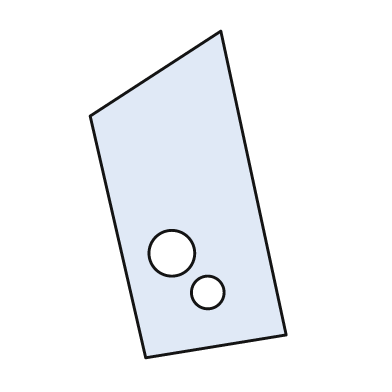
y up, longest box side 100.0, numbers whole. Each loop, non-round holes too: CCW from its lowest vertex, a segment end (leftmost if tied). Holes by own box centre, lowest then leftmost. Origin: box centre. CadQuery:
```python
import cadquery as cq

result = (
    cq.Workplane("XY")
    .moveTo(-13.0, -50.0)
    .lineTo(30.0, -43.0)
    .lineTo(10.0, 50.0)
    .lineTo(-30.0, 24.0)
    .close()
    .moveTo(6.0, -30.0)
    .circle(5.0)
    .moveTo(-5.0, -18.0)
    .circle(7.0)
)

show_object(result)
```